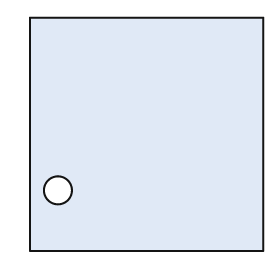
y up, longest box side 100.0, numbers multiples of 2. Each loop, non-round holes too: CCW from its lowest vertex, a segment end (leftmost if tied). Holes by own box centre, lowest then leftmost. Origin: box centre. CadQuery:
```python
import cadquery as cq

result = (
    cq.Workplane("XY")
    .moveTo(-50.0, -50.0)
    .lineTo(50.0, -50.0)
    .lineTo(50.0, 50.0)
    .lineTo(-50.0, 50.0)
    .close()
    .moveTo(-38.0, -24.0)
    .circle(6.0)
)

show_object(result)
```